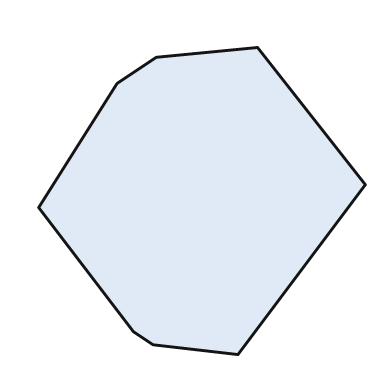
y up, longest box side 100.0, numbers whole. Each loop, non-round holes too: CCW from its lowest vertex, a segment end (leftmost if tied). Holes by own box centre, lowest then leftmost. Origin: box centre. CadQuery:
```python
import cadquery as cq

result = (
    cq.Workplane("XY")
    .moveTo(11.0, -47.0)
    .lineTo(50.0, 5.0)
    .lineTo(17.0, 47.0)
    .lineTo(-14.0, 44.0)
    .lineTo(-26.0, 36.0)
    .lineTo(-50.0, -2.0)
    .lineTo(-21.0, -40.0)
    .lineTo(-15.0, -44.0)
    .close()
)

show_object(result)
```